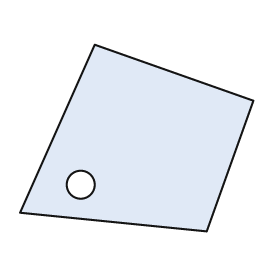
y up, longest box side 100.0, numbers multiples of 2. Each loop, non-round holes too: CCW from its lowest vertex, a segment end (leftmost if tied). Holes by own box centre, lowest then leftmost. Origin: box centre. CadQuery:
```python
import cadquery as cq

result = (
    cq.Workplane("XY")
    .moveTo(30.0, -40.0)
    .lineTo(50.0, 16.0)
    .lineTo(-18.0, 40.0)
    .lineTo(-50.0, -32.0)
    .close()
    .moveTo(-24.0, -20.0)
    .circle(6.0)
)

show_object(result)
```